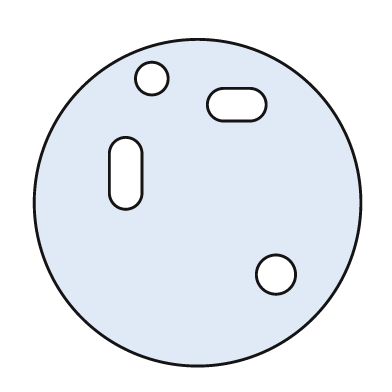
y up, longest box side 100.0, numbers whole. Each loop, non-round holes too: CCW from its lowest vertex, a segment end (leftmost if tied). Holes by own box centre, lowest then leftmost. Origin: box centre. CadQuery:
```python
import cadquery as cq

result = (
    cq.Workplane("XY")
    .moveTo(0.0, 0.0)
    .circle(50.0)
    .moveTo(24.0, -22.0)
    .circle(6.0)
    .moveTo(-27.0, 3.0)
    .threePointArc((-22.0, -2.0), (-17.0, 3.0))
    .lineTo(-17.0, 15.0)
    .threePointArc((-22.0, 20.0), (-27.0, 15.0))
    .close()
    .moveTo(8.0, 25.0)
    .lineTo(16.0, 25.0)
    .threePointArc((21.0, 30.0), (16.0, 35.0))
    .lineTo(8.0, 35.0)
    .threePointArc((3.0, 30.0), (8.0, 25.0))
    .close()
    .moveTo(-14.0, 38.0)
    .circle(5.0)
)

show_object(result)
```